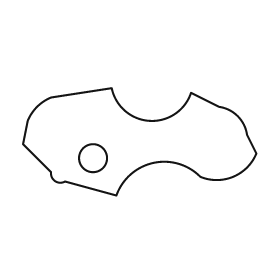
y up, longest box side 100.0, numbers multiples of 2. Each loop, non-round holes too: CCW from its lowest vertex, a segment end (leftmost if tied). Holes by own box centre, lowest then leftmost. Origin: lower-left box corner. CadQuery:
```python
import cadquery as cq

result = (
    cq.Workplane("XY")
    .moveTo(40.0, 0.0)
    .threePointArc((56.0, 14.0), (76.0, 8.0))
    .threePointArc((90.0, 8.0), (100.0, 18.0))
    .lineTo(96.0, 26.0)
    .threePointArc((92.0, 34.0), (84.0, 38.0))
    .lineTo(72.0, 44.0)
    .threePointArc((54.0, 32.0), (38.0, 46.0))
    .lineTo(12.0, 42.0)
    .threePointArc((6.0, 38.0), (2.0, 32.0))
    .lineTo(0.0, 22.0)
    .lineTo(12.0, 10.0)
    .threePointArc((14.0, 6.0), (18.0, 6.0))
    .close()
    .moveTo(30.0, 16.0)
    .circle(6.0)
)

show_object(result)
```